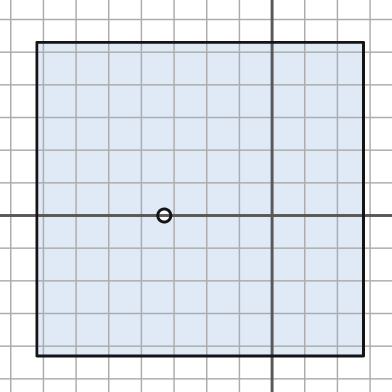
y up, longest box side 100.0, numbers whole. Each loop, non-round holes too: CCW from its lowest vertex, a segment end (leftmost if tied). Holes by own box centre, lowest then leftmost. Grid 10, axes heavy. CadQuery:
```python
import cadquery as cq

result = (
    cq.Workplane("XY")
    .moveTo(-72.0, -43.0)
    .lineTo(28.0, -43.0)
    .lineTo(28.0, 53.0)
    .lineTo(-72.0, 53.0)
    .close()
    .moveTo(-33.0, 0.0)
    .circle(2.0)
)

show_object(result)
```